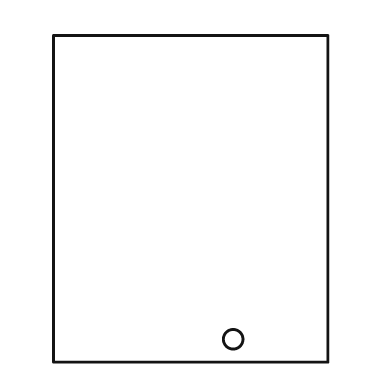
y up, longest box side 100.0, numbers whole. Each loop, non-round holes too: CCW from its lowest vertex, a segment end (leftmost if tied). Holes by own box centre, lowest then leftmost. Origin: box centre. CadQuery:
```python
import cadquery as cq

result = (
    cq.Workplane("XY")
    .moveTo(-42.0, -50.0)
    .lineTo(42.0, -50.0)
    .lineTo(42.0, 50.0)
    .lineTo(-42.0, 50.0)
    .close()
    .moveTo(13.0, -43.0)
    .circle(3.0)
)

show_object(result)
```